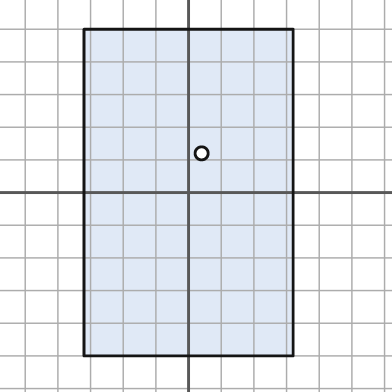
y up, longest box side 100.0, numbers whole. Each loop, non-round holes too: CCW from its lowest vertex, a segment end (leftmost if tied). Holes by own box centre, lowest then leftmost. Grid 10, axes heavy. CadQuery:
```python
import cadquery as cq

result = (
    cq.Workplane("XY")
    .moveTo(-32.0, -50.0)
    .lineTo(32.0, -50.0)
    .lineTo(32.0, 50.0)
    .lineTo(-32.0, 50.0)
    .close()
    .moveTo(4.0, 12.0)
    .circle(2.0)
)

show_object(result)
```